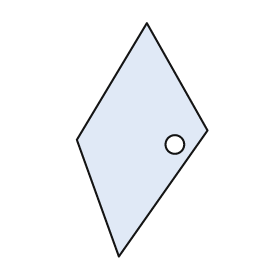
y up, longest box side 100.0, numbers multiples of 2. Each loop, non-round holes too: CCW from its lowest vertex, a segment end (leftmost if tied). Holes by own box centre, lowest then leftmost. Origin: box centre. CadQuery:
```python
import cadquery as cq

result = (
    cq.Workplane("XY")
    .moveTo(-10.0, -50.0)
    .lineTo(28.0, 4.0)
    .lineTo(2.0, 50.0)
    .lineTo(-28.0, 0.0)
    .close()
    .moveTo(14.0, -2.0)
    .circle(4.0)
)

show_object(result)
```